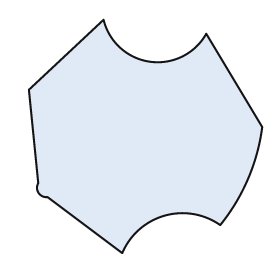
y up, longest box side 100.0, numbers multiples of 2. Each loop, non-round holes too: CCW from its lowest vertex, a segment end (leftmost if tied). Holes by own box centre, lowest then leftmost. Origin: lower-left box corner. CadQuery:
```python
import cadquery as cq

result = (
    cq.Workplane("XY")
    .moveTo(40.0, 0.0)
    .threePointArc((58.0, 16.0), (82.0, 12.0))
    .threePointArc((94.0, 32.0), (100.0, 54.0))
    .lineTo(76.0, 94.0)
    .threePointArc((52.0, 82.0), (32.0, 100.0))
    .lineTo(0.0, 70.0)
    .lineTo(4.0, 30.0)
    .threePointArc((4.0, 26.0), (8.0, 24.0))
    .close()
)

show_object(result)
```